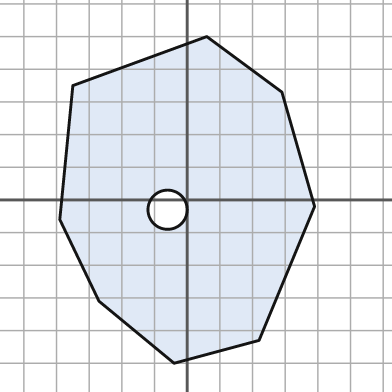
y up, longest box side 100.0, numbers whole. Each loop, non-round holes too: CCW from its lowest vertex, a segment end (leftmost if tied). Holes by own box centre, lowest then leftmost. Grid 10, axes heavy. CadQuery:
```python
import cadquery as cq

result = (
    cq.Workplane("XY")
    .moveTo(-4.0, -50.0)
    .lineTo(22.0, -43.0)
    .lineTo(39.0, -2.0)
    .lineTo(29.0, 33.0)
    .lineTo(6.0, 50.0)
    .lineTo(-35.0, 35.0)
    .lineTo(-39.0, -6.0)
    .lineTo(-27.0, -31.0)
    .close()
    .moveTo(-6.0, -3.0)
    .circle(6.0)
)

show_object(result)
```